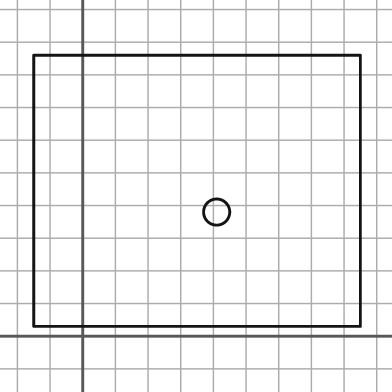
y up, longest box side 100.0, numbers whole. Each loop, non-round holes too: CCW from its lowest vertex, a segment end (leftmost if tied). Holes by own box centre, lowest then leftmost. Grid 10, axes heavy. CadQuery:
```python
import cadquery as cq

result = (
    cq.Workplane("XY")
    .moveTo(-15.0, 3.0)
    .lineTo(85.0, 3.0)
    .lineTo(85.0, 86.0)
    .lineTo(-15.0, 86.0)
    .close()
    .moveTo(41.0, 38.0)
    .circle(4.0)
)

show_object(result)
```